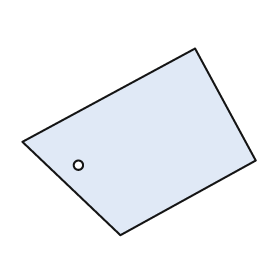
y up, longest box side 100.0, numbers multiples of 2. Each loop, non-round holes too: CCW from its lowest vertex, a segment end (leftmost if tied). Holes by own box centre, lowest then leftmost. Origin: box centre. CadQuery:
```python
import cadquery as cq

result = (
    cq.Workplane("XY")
    .moveTo(-8.0, -40.0)
    .lineTo(50.0, -8.0)
    .lineTo(24.0, 40.0)
    .lineTo(-50.0, 0.0)
    .close()
    .moveTo(-26.0, -10.0)
    .circle(2.0)
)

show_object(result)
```